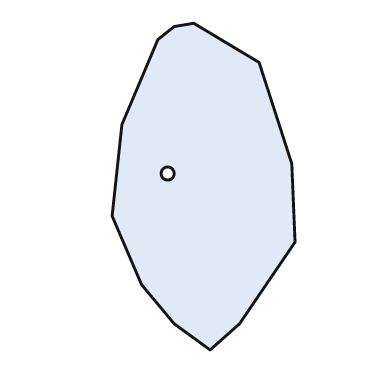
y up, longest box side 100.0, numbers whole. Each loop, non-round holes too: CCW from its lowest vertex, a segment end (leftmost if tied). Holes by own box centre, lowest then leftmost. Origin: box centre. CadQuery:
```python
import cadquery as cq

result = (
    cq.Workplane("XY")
    .moveTo(2.0, -50.0)
    .lineTo(11.0, -42.0)
    .lineTo(28.0, -17.0)
    .lineTo(27.0, 7.0)
    .lineTo(17.0, 38.0)
    .lineTo(-3.0, 50.0)
    .lineTo(-9.0, 49.0)
    .lineTo(-14.0, 45.0)
    .lineTo(-25.0, 19.0)
    .lineTo(-28.0, -9.0)
    .lineTo(-19.0, -30.0)
    .lineTo(-9.0, -42.0)
    .close()
    .moveTo(-11.0, 4.0)
    .circle(2.0)
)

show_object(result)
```